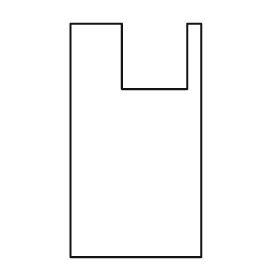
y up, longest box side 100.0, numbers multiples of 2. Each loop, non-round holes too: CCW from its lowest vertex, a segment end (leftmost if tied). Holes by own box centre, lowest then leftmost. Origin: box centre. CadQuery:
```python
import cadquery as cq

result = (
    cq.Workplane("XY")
    .moveTo(-28.0, -50.0)
    .lineTo(28.0, -50.0)
    .lineTo(28.0, 50.0)
    .lineTo(22.0, 50.0)
    .lineTo(22.0, 22.0)
    .lineTo(-6.0, 22.0)
    .lineTo(-6.0, 50.0)
    .lineTo(-28.0, 50.0)
    .close()
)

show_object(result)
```